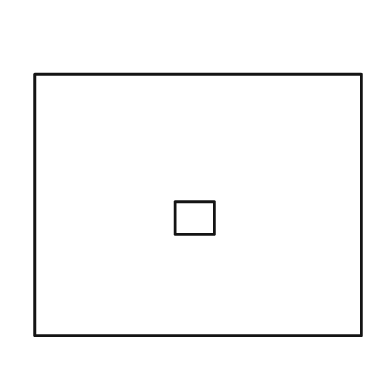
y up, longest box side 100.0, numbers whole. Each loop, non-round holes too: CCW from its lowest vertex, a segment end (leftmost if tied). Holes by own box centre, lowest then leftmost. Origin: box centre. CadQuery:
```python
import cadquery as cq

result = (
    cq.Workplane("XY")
    .moveTo(-50.0, -40.0)
    .lineTo(50.0, -40.0)
    .lineTo(50.0, 40.0)
    .lineTo(-50.0, 40.0)
    .close()
    .moveTo(-7.0, -9.0)
    .lineTo(5.0, -9.0)
    .lineTo(5.0, 1.0)
    .lineTo(-7.0, 1.0)
    .close()
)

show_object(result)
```